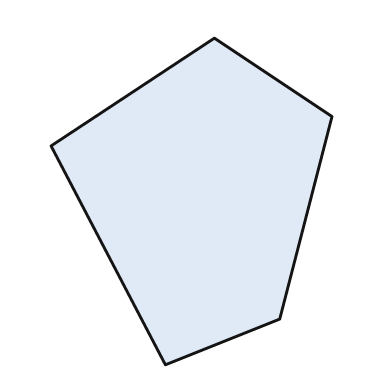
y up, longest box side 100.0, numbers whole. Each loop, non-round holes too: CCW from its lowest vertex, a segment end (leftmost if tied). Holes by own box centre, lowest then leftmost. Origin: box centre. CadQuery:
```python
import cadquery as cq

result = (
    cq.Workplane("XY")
    .moveTo(-8.0, -50.0)
    .lineTo(27.0, -36.0)
    .lineTo(43.0, 26.0)
    .lineTo(7.0, 50.0)
    .lineTo(-43.0, 17.0)
    .close()
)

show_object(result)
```